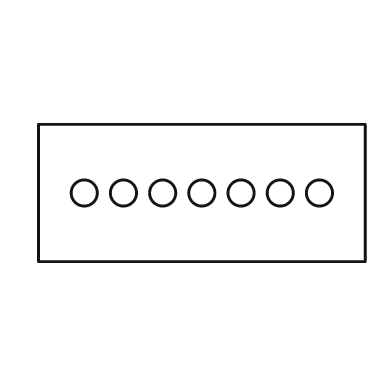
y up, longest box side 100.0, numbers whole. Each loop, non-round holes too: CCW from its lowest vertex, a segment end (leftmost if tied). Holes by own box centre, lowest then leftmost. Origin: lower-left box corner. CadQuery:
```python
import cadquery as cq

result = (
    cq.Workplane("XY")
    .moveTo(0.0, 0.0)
    .lineTo(100.0, 0.0)
    .lineTo(100.0, 42.0)
    .lineTo(0.0, 42.0)
    .close()
    .moveTo(14.0, 21.0)
    .circle(4.0)
    .moveTo(26.0, 21.0)
    .circle(4.0)
    .moveTo(38.0, 21.0)
    .circle(4.0)
    .moveTo(50.0, 21.0)
    .circle(4.0)
    .moveTo(62.0, 21.0)
    .circle(4.0)
    .moveTo(74.0, 21.0)
    .circle(4.0)
    .moveTo(86.0, 21.0)
    .circle(4.0)
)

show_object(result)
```